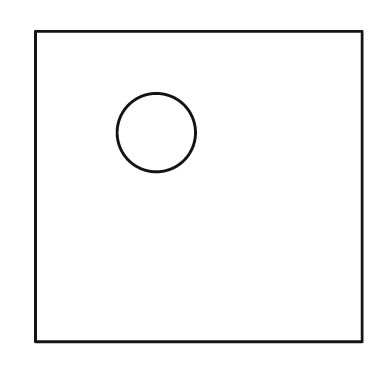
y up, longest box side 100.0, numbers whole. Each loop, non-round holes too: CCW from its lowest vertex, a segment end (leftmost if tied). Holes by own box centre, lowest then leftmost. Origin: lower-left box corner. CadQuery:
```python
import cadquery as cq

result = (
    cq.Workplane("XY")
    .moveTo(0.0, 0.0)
    .lineTo(100.0, 0.0)
    .lineTo(100.0, 95.0)
    .lineTo(0.0, 95.0)
    .close()
    .moveTo(37.0, 64.0)
    .circle(12.0)
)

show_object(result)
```